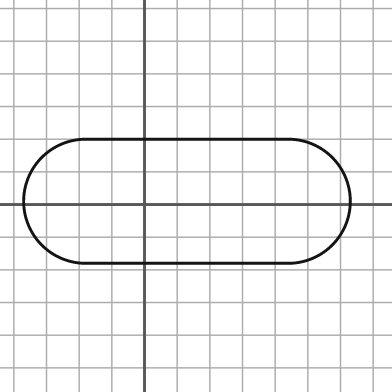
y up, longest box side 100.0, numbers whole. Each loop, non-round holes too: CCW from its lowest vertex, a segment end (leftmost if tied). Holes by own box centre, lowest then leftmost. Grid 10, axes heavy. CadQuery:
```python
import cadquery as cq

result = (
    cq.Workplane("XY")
    .moveTo(-18.0, -18.0)
    .lineTo(44.0, -18.0)
    .threePointArc((63.0, 1.0), (44.0, 20.0))
    .lineTo(-18.0, 20.0)
    .threePointArc((-37.0, 1.0), (-18.0, -18.0))
    .close()
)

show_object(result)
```